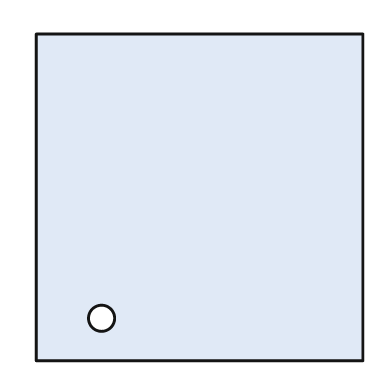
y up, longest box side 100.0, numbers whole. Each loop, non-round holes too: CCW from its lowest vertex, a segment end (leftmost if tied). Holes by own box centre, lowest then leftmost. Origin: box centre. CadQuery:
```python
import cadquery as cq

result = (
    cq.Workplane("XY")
    .moveTo(-50.0, -50.0)
    .lineTo(50.0, -50.0)
    .lineTo(50.0, 50.0)
    .lineTo(-50.0, 50.0)
    .close()
    .moveTo(-30.0, -37.0)
    .circle(4.0)
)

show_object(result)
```